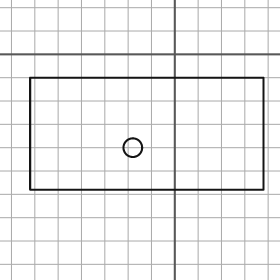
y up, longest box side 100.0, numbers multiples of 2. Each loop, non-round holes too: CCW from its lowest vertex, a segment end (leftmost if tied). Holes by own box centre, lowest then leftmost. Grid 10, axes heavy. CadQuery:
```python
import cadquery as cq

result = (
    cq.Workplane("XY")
    .moveTo(-62.0, -58.0)
    .lineTo(38.0, -58.0)
    .lineTo(38.0, -10.0)
    .lineTo(-62.0, -10.0)
    .close()
    .moveTo(-18.0, -40.0)
    .circle(4.0)
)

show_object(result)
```